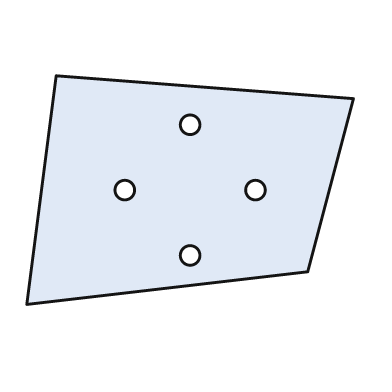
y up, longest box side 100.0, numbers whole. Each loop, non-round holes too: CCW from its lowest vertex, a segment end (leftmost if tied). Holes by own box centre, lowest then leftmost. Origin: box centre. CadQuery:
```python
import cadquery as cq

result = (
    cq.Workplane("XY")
    .moveTo(-50.0, -35.0)
    .lineTo(36.0, -25.0)
    .lineTo(50.0, 28.0)
    .lineTo(-41.0, 35.0)
    .close()
    .moveTo(0.0, -20.0)
    .circle(3.0)
    .moveTo(-20.0, 0.0)
    .circle(3.0)
    .moveTo(20.0, 0.0)
    .circle(3.0)
    .moveTo(0.0, 20.0)
    .circle(3.0)
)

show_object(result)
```